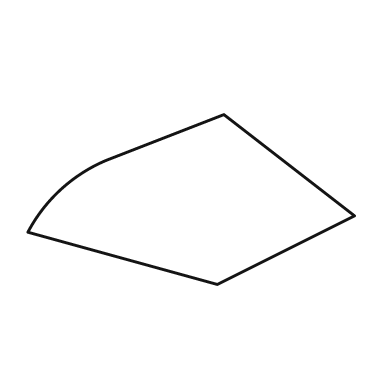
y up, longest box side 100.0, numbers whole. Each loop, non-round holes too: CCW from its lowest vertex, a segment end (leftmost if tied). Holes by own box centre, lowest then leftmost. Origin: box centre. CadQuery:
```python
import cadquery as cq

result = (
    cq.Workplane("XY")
    .moveTo(8.0, -26.0)
    .lineTo(50.0, -5.0)
    .lineTo(10.0, 26.0)
    .lineTo(-26.0, 12.0)
    .threePointArc((-40.0, 3.0), (-50.0, -10.0))
    .close()
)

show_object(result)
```